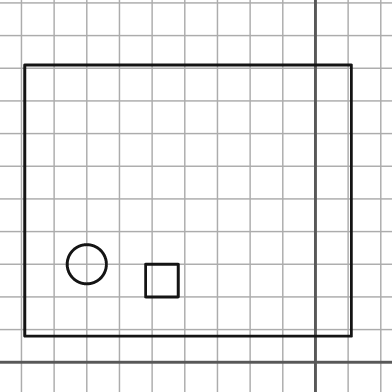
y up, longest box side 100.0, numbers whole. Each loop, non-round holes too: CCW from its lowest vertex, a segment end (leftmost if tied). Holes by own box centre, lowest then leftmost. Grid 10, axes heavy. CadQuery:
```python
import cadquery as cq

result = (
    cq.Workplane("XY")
    .moveTo(-89.0, 8.0)
    .lineTo(11.0, 8.0)
    .lineTo(11.0, 91.0)
    .lineTo(-89.0, 91.0)
    .close()
    .moveTo(-52.0, 20.0)
    .lineTo(-42.0, 20.0)
    .lineTo(-42.0, 30.0)
    .lineTo(-52.0, 30.0)
    .close()
    .moveTo(-70.0, 30.0)
    .circle(6.0)
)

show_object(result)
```